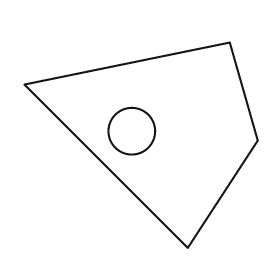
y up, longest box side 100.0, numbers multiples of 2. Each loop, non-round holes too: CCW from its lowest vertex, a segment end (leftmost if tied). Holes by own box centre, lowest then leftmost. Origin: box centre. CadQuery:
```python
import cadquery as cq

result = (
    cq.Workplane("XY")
    .moveTo(20.0, -44.0)
    .lineTo(50.0, 2.0)
    .lineTo(38.0, 44.0)
    .lineTo(-50.0, 26.0)
    .close()
    .moveTo(-4.0, 6.0)
    .circle(10.0)
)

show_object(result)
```